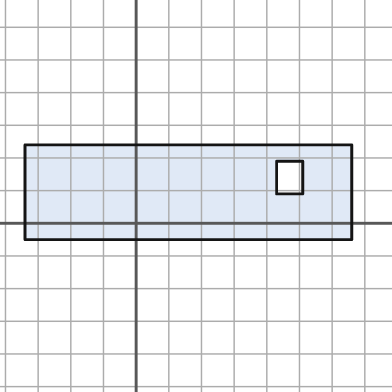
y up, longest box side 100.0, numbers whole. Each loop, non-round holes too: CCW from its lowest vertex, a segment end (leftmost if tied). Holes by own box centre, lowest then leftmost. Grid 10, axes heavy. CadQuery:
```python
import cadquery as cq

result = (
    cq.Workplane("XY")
    .moveTo(-34.0, -5.0)
    .lineTo(66.0, -5.0)
    .lineTo(66.0, 24.0)
    .lineTo(-34.0, 24.0)
    .close()
    .moveTo(43.0, 9.0)
    .lineTo(51.0, 9.0)
    .lineTo(51.0, 19.0)
    .lineTo(43.0, 19.0)
    .close()
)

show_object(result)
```